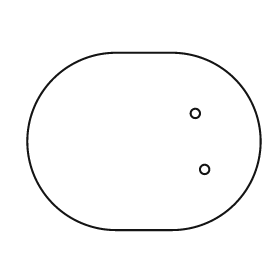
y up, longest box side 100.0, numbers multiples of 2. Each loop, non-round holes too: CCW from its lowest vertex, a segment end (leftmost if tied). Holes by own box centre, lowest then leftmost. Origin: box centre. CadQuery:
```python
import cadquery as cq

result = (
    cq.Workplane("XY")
    .moveTo(-12.0, -38.0)
    .lineTo(12.0, -38.0)
    .threePointArc((50.0, 0.0), (12.0, 38.0))
    .lineTo(-12.0, 38.0)
    .threePointArc((-50.0, 0.0), (-12.0, -38.0))
    .close()
    .moveTo(26.0, -12.0)
    .circle(2.0)
    .moveTo(22.0, 12.0)
    .circle(2.0)
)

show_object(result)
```